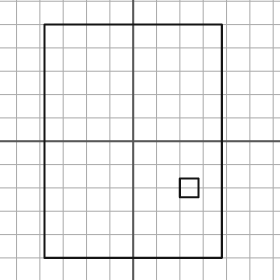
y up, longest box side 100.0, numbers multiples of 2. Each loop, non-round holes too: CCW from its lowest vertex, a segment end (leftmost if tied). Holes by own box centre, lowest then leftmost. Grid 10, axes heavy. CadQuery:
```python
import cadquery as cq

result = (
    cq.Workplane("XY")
    .moveTo(-38.0, -50.0)
    .lineTo(38.0, -50.0)
    .lineTo(38.0, 50.0)
    .lineTo(-38.0, 50.0)
    .close()
    .moveTo(20.0, -24.0)
    .lineTo(28.0, -24.0)
    .lineTo(28.0, -16.0)
    .lineTo(20.0, -16.0)
    .close()
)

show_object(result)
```